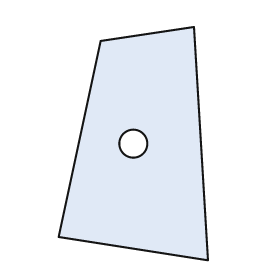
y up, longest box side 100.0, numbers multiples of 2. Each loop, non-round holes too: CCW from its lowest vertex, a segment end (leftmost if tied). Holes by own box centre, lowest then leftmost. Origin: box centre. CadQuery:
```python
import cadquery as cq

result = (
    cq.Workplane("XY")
    .moveTo(32.0, -50.0)
    .lineTo(26.0, 50.0)
    .lineTo(-14.0, 44.0)
    .lineTo(-32.0, -40.0)
    .close()
    .moveTo(0.0, 0.0)
    .circle(6.0)
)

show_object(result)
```